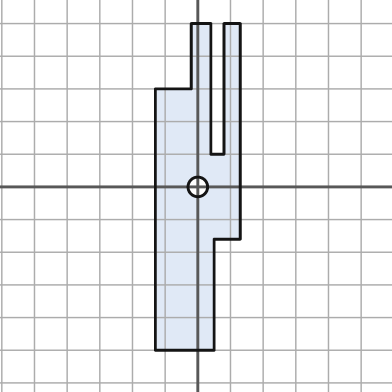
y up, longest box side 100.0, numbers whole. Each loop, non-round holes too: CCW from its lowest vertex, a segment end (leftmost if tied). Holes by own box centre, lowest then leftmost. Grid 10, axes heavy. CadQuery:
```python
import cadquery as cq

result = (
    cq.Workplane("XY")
    .moveTo(-13.0, -50.0)
    .lineTo(5.0, -50.0)
    .lineTo(5.0, -16.0)
    .lineTo(13.0, -16.0)
    .lineTo(13.0, 50.0)
    .lineTo(8.0, 50.0)
    .lineTo(8.0, 10.0)
    .lineTo(4.0, 10.0)
    .lineTo(4.0, 50.0)
    .lineTo(-2.0, 50.0)
    .lineTo(-2.0, 30.0)
    .lineTo(-13.0, 30.0)
    .close()
    .moveTo(0.0, 0.0)
    .circle(3.0)
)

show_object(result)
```